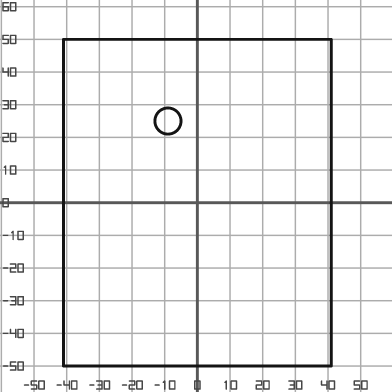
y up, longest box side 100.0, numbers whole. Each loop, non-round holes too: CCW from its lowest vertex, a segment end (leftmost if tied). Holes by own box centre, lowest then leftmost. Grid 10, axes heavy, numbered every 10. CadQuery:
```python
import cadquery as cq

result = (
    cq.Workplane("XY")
    .moveTo(-41.0, -50.0)
    .lineTo(41.0, -50.0)
    .lineTo(41.0, 50.0)
    .lineTo(-41.0, 50.0)
    .close()
    .moveTo(-9.0, 25.0)
    .circle(4.0)
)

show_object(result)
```